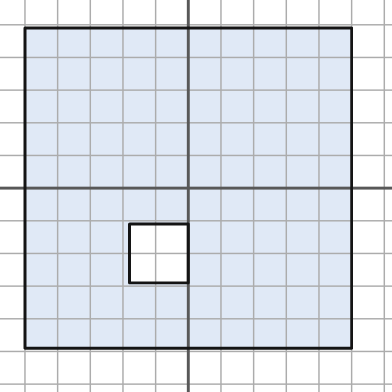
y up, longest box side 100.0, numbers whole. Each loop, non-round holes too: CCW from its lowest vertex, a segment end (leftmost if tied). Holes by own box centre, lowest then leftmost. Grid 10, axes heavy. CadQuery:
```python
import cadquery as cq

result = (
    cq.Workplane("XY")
    .moveTo(-50.0, -49.0)
    .lineTo(50.0, -49.0)
    .lineTo(50.0, 49.0)
    .lineTo(-50.0, 49.0)
    .close()
    .moveTo(-18.0, -29.0)
    .lineTo(0.0, -29.0)
    .lineTo(0.0, -11.0)
    .lineTo(-18.0, -11.0)
    .close()
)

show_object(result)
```